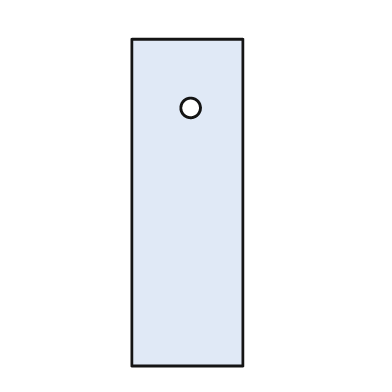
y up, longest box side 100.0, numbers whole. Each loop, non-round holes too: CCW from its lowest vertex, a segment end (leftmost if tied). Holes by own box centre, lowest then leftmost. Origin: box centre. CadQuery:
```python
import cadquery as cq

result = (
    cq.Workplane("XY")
    .moveTo(-17.0, -50.0)
    .lineTo(17.0, -50.0)
    .lineTo(17.0, 50.0)
    .lineTo(-17.0, 50.0)
    .close()
    .moveTo(1.0, 29.0)
    .circle(3.0)
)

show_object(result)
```